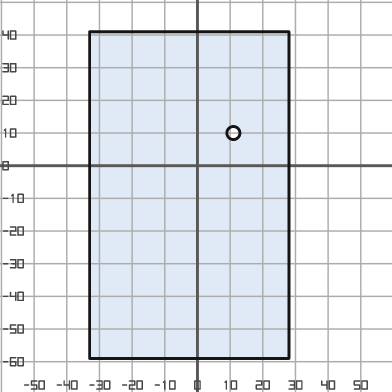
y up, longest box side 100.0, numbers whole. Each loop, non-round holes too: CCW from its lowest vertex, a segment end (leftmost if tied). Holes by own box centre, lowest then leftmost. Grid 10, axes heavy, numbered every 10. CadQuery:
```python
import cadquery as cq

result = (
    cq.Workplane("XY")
    .moveTo(-33.0, -59.0)
    .lineTo(28.0, -59.0)
    .lineTo(28.0, 41.0)
    .lineTo(-33.0, 41.0)
    .close()
    .moveTo(11.0, 10.0)
    .circle(2.0)
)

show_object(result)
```